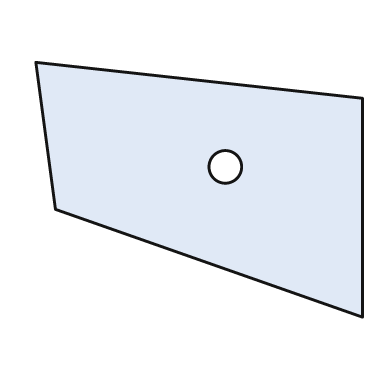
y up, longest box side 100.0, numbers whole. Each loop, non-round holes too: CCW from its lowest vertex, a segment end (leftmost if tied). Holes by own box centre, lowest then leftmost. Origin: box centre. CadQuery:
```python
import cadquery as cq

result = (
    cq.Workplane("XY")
    .moveTo(50.0, -39.0)
    .lineTo(50.0, 28.0)
    .lineTo(-50.0, 39.0)
    .lineTo(-44.0, -6.0)
    .close()
    .moveTo(8.0, 7.0)
    .circle(5.0)
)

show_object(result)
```